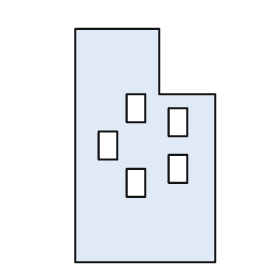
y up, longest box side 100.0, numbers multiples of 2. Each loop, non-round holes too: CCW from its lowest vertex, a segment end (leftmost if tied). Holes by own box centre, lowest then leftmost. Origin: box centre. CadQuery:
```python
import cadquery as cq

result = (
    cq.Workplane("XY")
    .moveTo(-30.0, -50.0)
    .lineTo(30.0, -50.0)
    .lineTo(30.0, 22.0)
    .lineTo(6.0, 22.0)
    .lineTo(6.0, 50.0)
    .lineTo(-30.0, 50.0)
    .close()
    .moveTo(-8.0, -22.0)
    .lineTo(0.0, -22.0)
    .lineTo(0.0, -10.0)
    .lineTo(-8.0, -10.0)
    .close()
    .moveTo(10.0, -16.0)
    .lineTo(18.0, -16.0)
    .lineTo(18.0, -4.0)
    .lineTo(10.0, -4.0)
    .close()
    .moveTo(-20.0, -6.0)
    .lineTo(-12.0, -6.0)
    .lineTo(-12.0, 6.0)
    .lineTo(-20.0, 6.0)
    .close()
    .moveTo(10.0, 4.0)
    .lineTo(18.0, 4.0)
    .lineTo(18.0, 16.0)
    .lineTo(10.0, 16.0)
    .close()
    .moveTo(-8.0, 10.0)
    .lineTo(0.0, 10.0)
    .lineTo(0.0, 22.0)
    .lineTo(-8.0, 22.0)
    .close()
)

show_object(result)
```